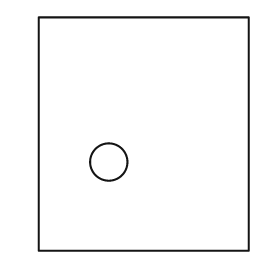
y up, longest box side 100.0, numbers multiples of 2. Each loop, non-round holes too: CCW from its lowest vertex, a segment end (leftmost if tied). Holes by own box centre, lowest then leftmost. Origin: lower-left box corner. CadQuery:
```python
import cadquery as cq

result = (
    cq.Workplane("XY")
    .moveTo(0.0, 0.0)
    .lineTo(90.0, 0.0)
    .lineTo(90.0, 100.0)
    .lineTo(0.0, 100.0)
    .close()
    .moveTo(30.0, 38.0)
    .circle(8.0)
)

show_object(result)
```